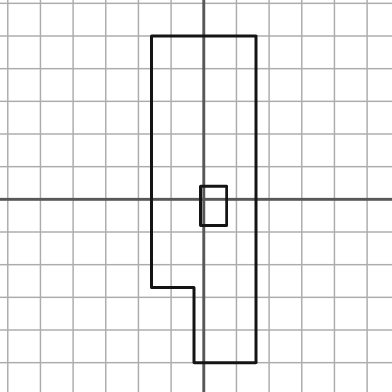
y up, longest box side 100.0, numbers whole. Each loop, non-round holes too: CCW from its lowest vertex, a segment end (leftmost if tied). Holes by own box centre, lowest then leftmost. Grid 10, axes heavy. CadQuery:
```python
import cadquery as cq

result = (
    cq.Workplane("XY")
    .moveTo(-3.0, -50.0)
    .lineTo(16.0, -50.0)
    .lineTo(16.0, 50.0)
    .lineTo(-16.0, 50.0)
    .lineTo(-16.0, -27.0)
    .lineTo(-3.0, -27.0)
    .close()
    .moveTo(-1.0, -8.0)
    .lineTo(7.0, -8.0)
    .lineTo(7.0, 4.0)
    .lineTo(-1.0, 4.0)
    .close()
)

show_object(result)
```